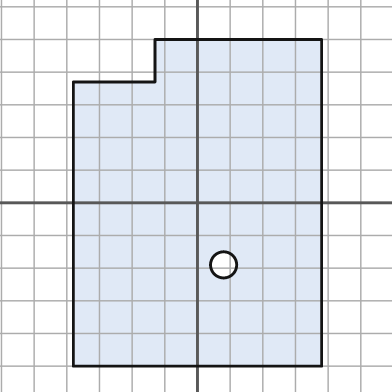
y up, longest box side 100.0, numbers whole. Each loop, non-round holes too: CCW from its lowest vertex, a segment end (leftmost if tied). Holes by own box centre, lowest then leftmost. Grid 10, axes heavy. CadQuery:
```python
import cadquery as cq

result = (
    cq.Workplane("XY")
    .moveTo(-38.0, -50.0)
    .lineTo(38.0, -50.0)
    .lineTo(38.0, 50.0)
    .lineTo(-13.0, 50.0)
    .lineTo(-13.0, 37.0)
    .lineTo(-38.0, 37.0)
    .close()
    .moveTo(8.0, -19.0)
    .circle(4.0)
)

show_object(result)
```